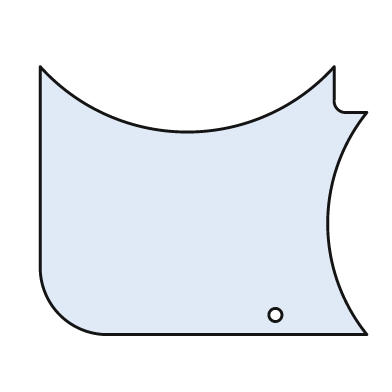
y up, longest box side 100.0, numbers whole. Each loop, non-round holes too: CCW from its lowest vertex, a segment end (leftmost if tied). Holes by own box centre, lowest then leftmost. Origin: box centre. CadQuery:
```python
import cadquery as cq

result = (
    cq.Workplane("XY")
    .moveTo(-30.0, -41.0)
    .lineTo(50.0, -41.0)
    .threePointArc((38.0, -7.0), (50.0, 27.0))
    .lineTo(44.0, 27.0)
    .threePointArc((41.0, 28.0), (40.0, 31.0))
    .lineTo(40.0, 41.0)
    .threePointArc((-5.0, 21.0), (-50.0, 41.0))
    .lineTo(-50.0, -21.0)
    .threePointArc((-44.0, -35.0), (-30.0, -41.0))
    .close()
    .moveTo(22.0, -35.0)
    .circle(2.0)
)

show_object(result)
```